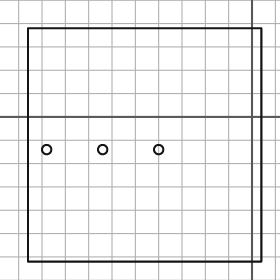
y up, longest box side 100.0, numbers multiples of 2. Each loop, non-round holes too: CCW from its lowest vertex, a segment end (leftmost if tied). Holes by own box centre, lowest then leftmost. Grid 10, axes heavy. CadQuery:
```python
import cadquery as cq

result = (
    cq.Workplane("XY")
    .moveTo(-96.0, -62.0)
    .lineTo(4.0, -62.0)
    .lineTo(4.0, 38.0)
    .lineTo(-96.0, 38.0)
    .close()
    .moveTo(-88.0, -14.0)
    .circle(2.0)
    .moveTo(-64.0, -14.0)
    .circle(2.0)
    .moveTo(-40.0, -14.0)
    .circle(2.0)
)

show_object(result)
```